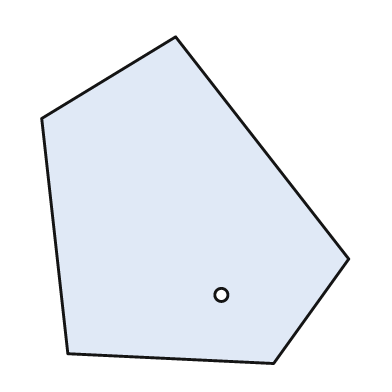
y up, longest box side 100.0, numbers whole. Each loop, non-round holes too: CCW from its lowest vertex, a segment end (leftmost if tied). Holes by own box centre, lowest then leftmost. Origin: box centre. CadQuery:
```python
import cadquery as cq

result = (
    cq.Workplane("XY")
    .moveTo(24.0, -50.0)
    .lineTo(47.0, -18.0)
    .lineTo(-6.0, 50.0)
    .lineTo(-47.0, 25.0)
    .lineTo(-39.0, -47.0)
    .close()
    .moveTo(8.0, -29.0)
    .circle(2.0)
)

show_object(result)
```